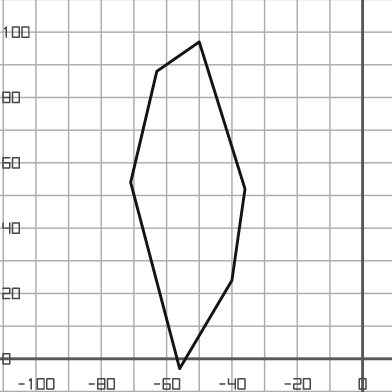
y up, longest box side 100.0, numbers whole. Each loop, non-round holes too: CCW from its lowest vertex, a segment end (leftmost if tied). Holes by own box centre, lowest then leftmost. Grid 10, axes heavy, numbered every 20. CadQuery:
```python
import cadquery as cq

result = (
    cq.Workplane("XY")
    .moveTo(-56.0, -3.0)
    .lineTo(-40.0, 24.0)
    .lineTo(-36.0, 52.0)
    .lineTo(-50.0, 97.0)
    .lineTo(-63.0, 88.0)
    .lineTo(-71.0, 54.0)
    .close()
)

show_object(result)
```